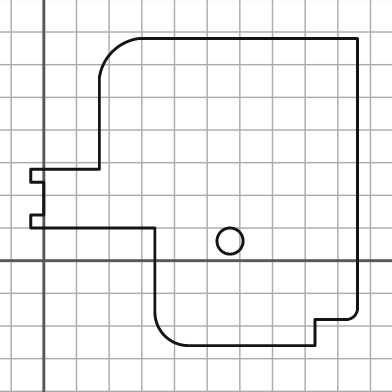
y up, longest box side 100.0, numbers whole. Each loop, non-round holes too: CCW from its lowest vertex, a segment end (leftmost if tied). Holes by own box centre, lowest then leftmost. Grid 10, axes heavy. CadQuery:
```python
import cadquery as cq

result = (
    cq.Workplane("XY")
    .moveTo(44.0, -26.0)
    .lineTo(83.0, -26.0)
    .lineTo(83.0, -18.0)
    .lineTo(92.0, -18.0)
    .threePointArc((95.0, -17.0), (96.0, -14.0))
    .lineTo(96.0, 68.0)
    .lineTo(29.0, 68.0)
    .threePointArc((21.0, 64.0), (17.0, 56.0))
    .lineTo(17.0, 28.0)
    .lineTo(-4.0, 28.0)
    .lineTo(-4.0, 24.0)
    .lineTo(0.0, 24.0)
    .lineTo(0.0, 14.0)
    .lineTo(-4.0, 14.0)
    .lineTo(-4.0, 10.0)
    .lineTo(34.0, 10.0)
    .lineTo(34.0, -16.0)
    .threePointArc((37.0, -23.0), (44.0, -26.0))
    .close()
    .moveTo(57.0, 6.0)
    .circle(4.0)
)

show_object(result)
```